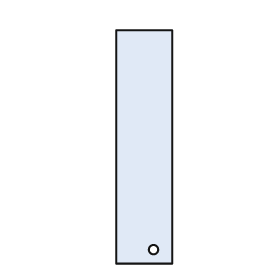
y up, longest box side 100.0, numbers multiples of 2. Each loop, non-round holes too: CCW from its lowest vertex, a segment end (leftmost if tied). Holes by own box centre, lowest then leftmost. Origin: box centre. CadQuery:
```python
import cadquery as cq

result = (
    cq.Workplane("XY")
    .moveTo(-12.0, -50.0)
    .lineTo(12.0, -50.0)
    .lineTo(12.0, 50.0)
    .lineTo(-12.0, 50.0)
    .close()
    .moveTo(4.0, -44.0)
    .circle(2.0)
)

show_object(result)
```